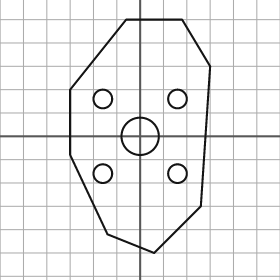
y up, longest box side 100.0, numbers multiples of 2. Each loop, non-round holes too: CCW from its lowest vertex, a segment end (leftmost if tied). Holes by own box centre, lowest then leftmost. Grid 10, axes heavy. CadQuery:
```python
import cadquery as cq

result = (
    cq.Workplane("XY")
    .moveTo(6.0, -50.0)
    .lineTo(26.0, -30.0)
    .lineTo(30.0, 30.0)
    .lineTo(18.0, 50.0)
    .lineTo(-6.0, 50.0)
    .lineTo(-30.0, 20.0)
    .lineTo(-30.0, -8.0)
    .lineTo(-14.0, -42.0)
    .close()
    .moveTo(-16.0, -16.0)
    .circle(4.0)
    .moveTo(16.0, -16.0)
    .circle(4.0)
    .moveTo(0.0, 0.0)
    .circle(8.0)
    .moveTo(-16.0, 16.0)
    .circle(4.0)
    .moveTo(16.0, 16.0)
    .circle(4.0)
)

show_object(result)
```